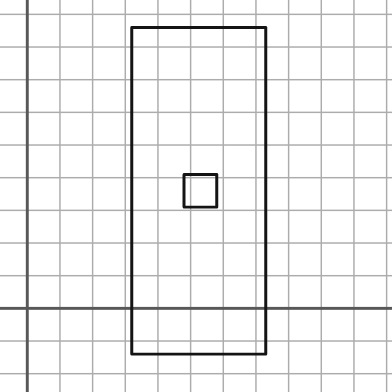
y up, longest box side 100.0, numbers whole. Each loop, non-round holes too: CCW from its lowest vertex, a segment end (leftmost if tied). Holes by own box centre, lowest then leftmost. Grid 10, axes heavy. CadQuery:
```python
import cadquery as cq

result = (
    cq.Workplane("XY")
    .moveTo(32.0, -14.0)
    .lineTo(73.0, -14.0)
    .lineTo(73.0, 86.0)
    .lineTo(32.0, 86.0)
    .close()
    .moveTo(48.0, 31.0)
    .lineTo(58.0, 31.0)
    .lineTo(58.0, 41.0)
    .lineTo(48.0, 41.0)
    .close()
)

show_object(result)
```